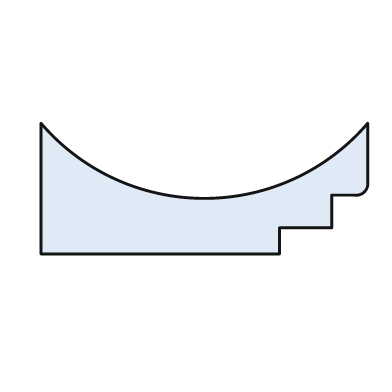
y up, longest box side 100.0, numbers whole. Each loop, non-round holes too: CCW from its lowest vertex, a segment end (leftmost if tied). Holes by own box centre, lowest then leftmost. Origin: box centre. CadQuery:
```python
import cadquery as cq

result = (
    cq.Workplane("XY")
    .moveTo(-50.0, -20.0)
    .lineTo(23.0, -20.0)
    .lineTo(23.0, -12.0)
    .lineTo(39.0, -12.0)
    .lineTo(39.0, -2.0)
    .lineTo(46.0, -2.0)
    .threePointArc((49.0, -1.0), (50.0, 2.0))
    .lineTo(50.0, 20.0)
    .threePointArc((0.0, -3.0), (-50.0, 20.0))
    .close()
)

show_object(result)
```